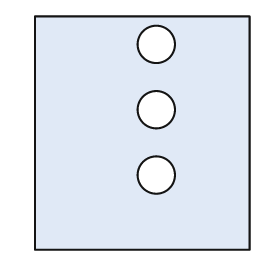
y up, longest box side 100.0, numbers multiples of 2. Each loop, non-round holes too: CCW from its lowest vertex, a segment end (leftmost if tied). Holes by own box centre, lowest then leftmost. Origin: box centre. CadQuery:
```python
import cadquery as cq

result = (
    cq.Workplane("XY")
    .moveTo(-46.0, -50.0)
    .lineTo(46.0, -50.0)
    .lineTo(46.0, 50.0)
    .lineTo(-46.0, 50.0)
    .close()
    .moveTo(6.0, -18.0)
    .circle(8.0)
    .moveTo(6.0, 10.0)
    .circle(8.0)
    .moveTo(6.0, 38.0)
    .circle(8.0)
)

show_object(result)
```